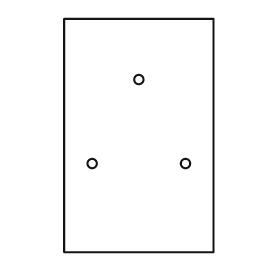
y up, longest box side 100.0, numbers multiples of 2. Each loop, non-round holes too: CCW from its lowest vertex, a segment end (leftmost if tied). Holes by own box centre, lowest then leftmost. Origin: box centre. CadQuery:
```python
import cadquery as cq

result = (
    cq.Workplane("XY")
    .moveTo(-32.0, -50.0)
    .lineTo(32.0, -50.0)
    .lineTo(32.0, 50.0)
    .lineTo(-32.0, 50.0)
    .close()
    .moveTo(-20.0, -12.0)
    .circle(2.0)
    .moveTo(20.0, -12.0)
    .circle(2.0)
    .moveTo(0.0, 24.0)
    .circle(2.0)
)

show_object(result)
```